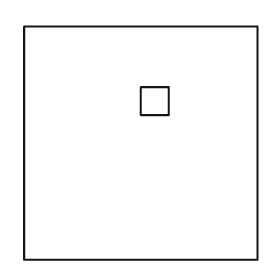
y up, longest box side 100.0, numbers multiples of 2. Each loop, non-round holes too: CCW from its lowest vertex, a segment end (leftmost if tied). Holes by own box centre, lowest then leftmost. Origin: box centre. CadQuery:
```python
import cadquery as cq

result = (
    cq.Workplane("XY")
    .moveTo(-50.0, -50.0)
    .lineTo(50.0, -50.0)
    .lineTo(50.0, 50.0)
    .lineTo(-50.0, 50.0)
    .close()
    .moveTo(0.0, 12.0)
    .lineTo(12.0, 12.0)
    .lineTo(12.0, 24.0)
    .lineTo(0.0, 24.0)
    .close()
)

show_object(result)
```